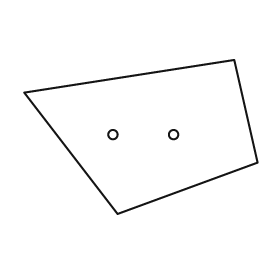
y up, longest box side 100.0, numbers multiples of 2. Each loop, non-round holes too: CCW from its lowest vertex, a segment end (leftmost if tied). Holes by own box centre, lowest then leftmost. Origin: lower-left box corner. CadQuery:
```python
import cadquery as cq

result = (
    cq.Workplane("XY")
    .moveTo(40.0, 0.0)
    .lineTo(100.0, 22.0)
    .lineTo(90.0, 66.0)
    .lineTo(0.0, 52.0)
    .close()
    .moveTo(38.0, 34.0)
    .circle(2.0)
    .moveTo(64.0, 34.0)
    .circle(2.0)
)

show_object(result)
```